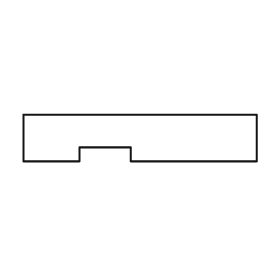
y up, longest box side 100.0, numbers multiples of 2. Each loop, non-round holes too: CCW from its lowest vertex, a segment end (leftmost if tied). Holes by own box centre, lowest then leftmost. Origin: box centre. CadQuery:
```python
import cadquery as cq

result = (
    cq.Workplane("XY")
    .moveTo(-50.0, -10.0)
    .lineTo(-26.0, -10.0)
    .lineTo(-26.0, -4.0)
    .lineTo(-4.0, -4.0)
    .lineTo(-4.0, -10.0)
    .lineTo(50.0, -10.0)
    .lineTo(50.0, 10.0)
    .lineTo(-50.0, 10.0)
    .close()
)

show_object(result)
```